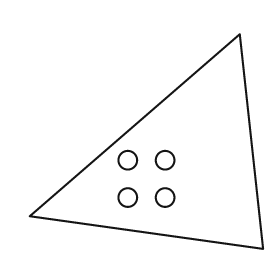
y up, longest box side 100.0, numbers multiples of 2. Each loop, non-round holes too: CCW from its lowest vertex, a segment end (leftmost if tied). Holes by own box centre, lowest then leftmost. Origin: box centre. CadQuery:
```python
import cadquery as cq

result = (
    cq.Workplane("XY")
    .moveTo(50.0, -46.0)
    .lineTo(40.0, 46.0)
    .lineTo(-50.0, -32.0)
    .close()
    .moveTo(-8.0, -24.0)
    .circle(4.0)
    .moveTo(8.0, -24.0)
    .circle(4.0)
    .moveTo(-8.0, -8.0)
    .circle(4.0)
    .moveTo(8.0, -8.0)
    .circle(4.0)
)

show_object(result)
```